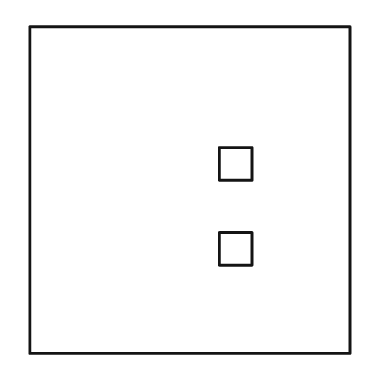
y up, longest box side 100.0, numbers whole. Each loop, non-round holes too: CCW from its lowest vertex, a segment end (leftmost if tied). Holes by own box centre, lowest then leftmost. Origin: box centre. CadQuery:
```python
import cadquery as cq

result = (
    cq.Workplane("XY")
    .moveTo(-49.0, -50.0)
    .lineTo(49.0, -50.0)
    .lineTo(49.0, 50.0)
    .lineTo(-49.0, 50.0)
    .close()
    .moveTo(9.0, -23.0)
    .lineTo(19.0, -23.0)
    .lineTo(19.0, -13.0)
    .lineTo(9.0, -13.0)
    .close()
    .moveTo(9.0, 3.0)
    .lineTo(19.0, 3.0)
    .lineTo(19.0, 13.0)
    .lineTo(9.0, 13.0)
    .close()
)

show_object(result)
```